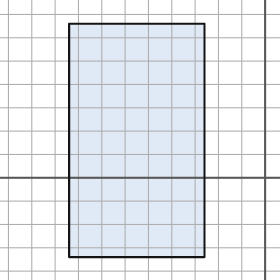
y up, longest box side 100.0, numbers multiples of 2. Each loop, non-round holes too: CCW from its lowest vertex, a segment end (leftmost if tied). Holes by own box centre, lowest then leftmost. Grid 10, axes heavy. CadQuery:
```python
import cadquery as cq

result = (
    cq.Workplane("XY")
    .moveTo(-84.0, -34.0)
    .lineTo(-26.0, -34.0)
    .lineTo(-26.0, 66.0)
    .lineTo(-84.0, 66.0)
    .close()
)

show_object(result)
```